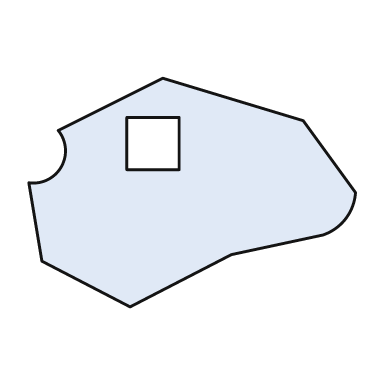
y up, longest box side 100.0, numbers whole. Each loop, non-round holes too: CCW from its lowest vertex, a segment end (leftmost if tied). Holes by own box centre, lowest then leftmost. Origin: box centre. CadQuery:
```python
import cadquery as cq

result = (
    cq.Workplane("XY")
    .moveTo(-19.0, -35.0)
    .lineTo(12.0, -19.0)
    .lineTo(40.0, -13.0)
    .threePointArc((47.0, -8.0), (50.0, 0.0))
    .lineTo(34.0, 22.0)
    .lineTo(-9.0, 35.0)
    .lineTo(-41.0, 19.0)
    .threePointArc((-40.0, 8.0), (-50.0, 3.0))
    .lineTo(-46.0, -21.0)
    .close()
    .moveTo(-20.0, 7.0)
    .lineTo(-4.0, 7.0)
    .lineTo(-4.0, 23.0)
    .lineTo(-20.0, 23.0)
    .close()
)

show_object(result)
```